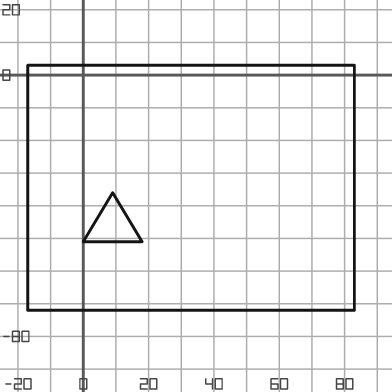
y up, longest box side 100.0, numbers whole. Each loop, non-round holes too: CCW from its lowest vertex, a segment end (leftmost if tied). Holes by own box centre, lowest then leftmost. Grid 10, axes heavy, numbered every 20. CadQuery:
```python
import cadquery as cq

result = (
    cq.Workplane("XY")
    .moveTo(-17.0, -72.0)
    .lineTo(83.0, -72.0)
    .lineTo(83.0, 3.0)
    .lineTo(-17.0, 3.0)
    .close()
    .moveTo(0.0, -51.0)
    .lineTo(18.0, -51.0)
    .lineTo(9.0, -36.0)
    .close()
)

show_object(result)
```